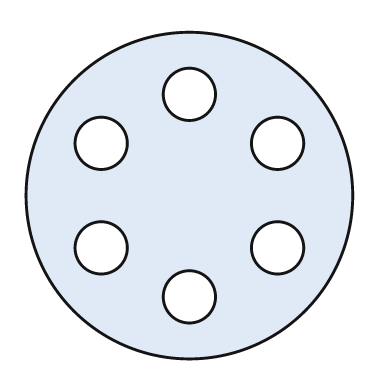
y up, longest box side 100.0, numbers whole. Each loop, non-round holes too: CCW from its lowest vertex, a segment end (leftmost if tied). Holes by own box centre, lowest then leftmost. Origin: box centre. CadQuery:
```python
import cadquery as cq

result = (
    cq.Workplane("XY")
    .moveTo(0.0, 0.0)
    .circle(50.0)
    .moveTo(0.0, -31.0)
    .circle(8.0)
    .moveTo(-27.0, -16.0)
    .circle(8.0)
    .moveTo(27.0, -16.0)
    .circle(8.0)
    .moveTo(-27.0, 16.0)
    .circle(8.0)
    .moveTo(27.0, 16.0)
    .circle(8.0)
    .moveTo(0.0, 31.0)
    .circle(8.0)
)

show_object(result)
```